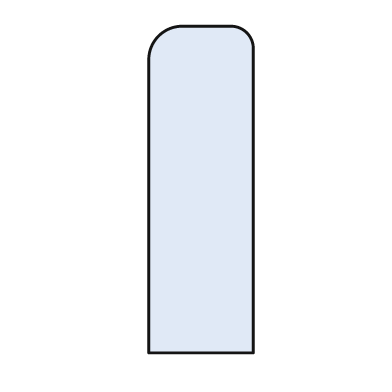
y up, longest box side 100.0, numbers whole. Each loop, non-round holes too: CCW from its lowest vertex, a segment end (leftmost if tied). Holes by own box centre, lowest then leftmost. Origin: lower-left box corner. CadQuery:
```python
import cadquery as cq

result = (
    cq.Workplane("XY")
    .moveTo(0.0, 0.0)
    .lineTo(32.0, 0.0)
    .lineTo(32.0, 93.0)
    .threePointArc((30.0, 98.0), (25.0, 100.0))
    .lineTo(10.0, 100.0)
    .threePointArc((3.0, 97.0), (0.0, 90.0))
    .close()
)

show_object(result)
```